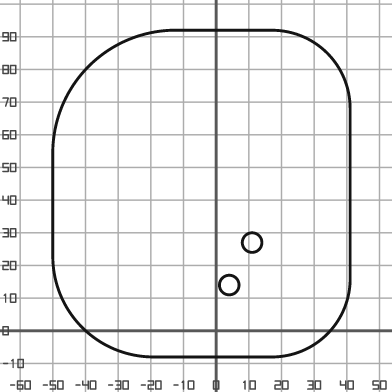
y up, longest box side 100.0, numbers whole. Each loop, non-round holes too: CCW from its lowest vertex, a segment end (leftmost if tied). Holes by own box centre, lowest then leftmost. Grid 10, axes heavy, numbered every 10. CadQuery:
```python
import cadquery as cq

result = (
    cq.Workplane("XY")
    .moveTo(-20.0, -8.0)
    .lineTo(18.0, -8.0)
    .threePointArc((34.0, -1.0), (41.0, 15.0))
    .lineTo(41.0, 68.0)
    .threePointArc((34.0, 85.0), (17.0, 92.0))
    .lineTo(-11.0, 92.0)
    .threePointArc((-39.0, 81.0), (-50.0, 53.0))
    .lineTo(-50.0, 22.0)
    .threePointArc((-41.0, 1.0), (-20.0, -8.0))
    .close()
    .moveTo(4.0, 14.0)
    .circle(3.0)
    .moveTo(11.0, 27.0)
    .circle(3.0)
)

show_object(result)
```